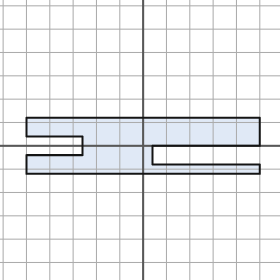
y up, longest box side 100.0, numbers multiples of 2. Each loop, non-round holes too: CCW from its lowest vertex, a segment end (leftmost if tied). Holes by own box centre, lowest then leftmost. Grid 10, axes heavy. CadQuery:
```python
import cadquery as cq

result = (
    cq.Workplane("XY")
    .moveTo(-50.0, -12.0)
    .lineTo(50.0, -12.0)
    .lineTo(50.0, -8.0)
    .lineTo(4.0, -8.0)
    .lineTo(4.0, 0.0)
    .lineTo(50.0, 0.0)
    .lineTo(50.0, 12.0)
    .lineTo(-50.0, 12.0)
    .lineTo(-50.0, 4.0)
    .lineTo(-26.0, 4.0)
    .lineTo(-26.0, -4.0)
    .lineTo(-50.0, -4.0)
    .close()
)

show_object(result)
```